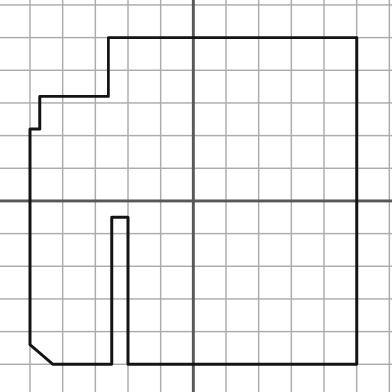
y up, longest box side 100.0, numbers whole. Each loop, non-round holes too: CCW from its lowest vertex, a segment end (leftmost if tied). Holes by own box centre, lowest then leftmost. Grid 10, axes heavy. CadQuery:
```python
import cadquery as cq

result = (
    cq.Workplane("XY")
    .moveTo(-43.0, -50.0)
    .lineTo(-25.0, -50.0)
    .lineTo(-25.0, -5.0)
    .lineTo(-20.0, -5.0)
    .lineTo(-20.0, -50.0)
    .lineTo(50.0, -50.0)
    .lineTo(50.0, 50.0)
    .lineTo(-26.0, 50.0)
    .lineTo(-26.0, 32.0)
    .lineTo(-47.0, 32.0)
    .lineTo(-47.0, 22.0)
    .lineTo(-50.0, 22.0)
    .lineTo(-50.0, -44.0)
    .close()
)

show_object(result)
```